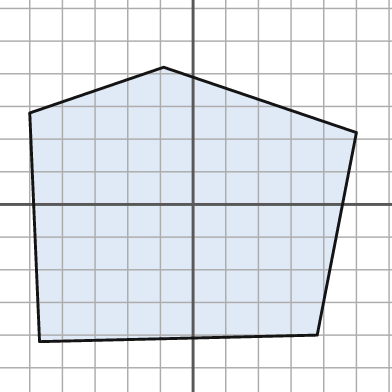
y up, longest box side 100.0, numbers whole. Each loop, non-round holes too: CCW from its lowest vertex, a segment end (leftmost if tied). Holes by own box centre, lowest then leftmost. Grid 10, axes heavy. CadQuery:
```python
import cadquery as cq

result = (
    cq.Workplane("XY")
    .moveTo(-47.0, -42.0)
    .lineTo(38.0, -40.0)
    .lineTo(50.0, 22.0)
    .lineTo(-9.0, 42.0)
    .lineTo(-50.0, 28.0)
    .close()
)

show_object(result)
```